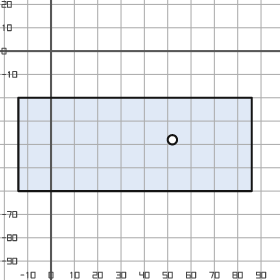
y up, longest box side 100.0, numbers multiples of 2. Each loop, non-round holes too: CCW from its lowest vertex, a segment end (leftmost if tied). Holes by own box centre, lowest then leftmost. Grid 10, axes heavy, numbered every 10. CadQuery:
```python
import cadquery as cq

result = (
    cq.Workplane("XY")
    .moveTo(-14.0, -60.0)
    .lineTo(86.0, -60.0)
    .lineTo(86.0, -20.0)
    .lineTo(-14.0, -20.0)
    .close()
    .moveTo(52.0, -38.0)
    .circle(2.0)
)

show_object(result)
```